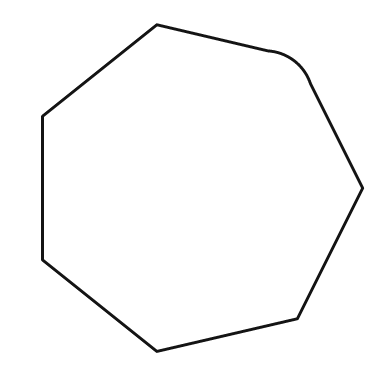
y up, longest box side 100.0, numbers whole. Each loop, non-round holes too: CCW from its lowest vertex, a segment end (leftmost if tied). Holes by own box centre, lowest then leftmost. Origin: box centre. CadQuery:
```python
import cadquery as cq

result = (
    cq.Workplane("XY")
    .moveTo(-14.0, -50.0)
    .lineTo(29.0, -40.0)
    .lineTo(49.0, 0.0)
    .lineTo(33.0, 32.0)
    .threePointArc((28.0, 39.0), (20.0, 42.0))
    .lineTo(-14.0, 50.0)
    .lineTo(-49.0, 22.0)
    .lineTo(-49.0, -22.0)
    .close()
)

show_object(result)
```